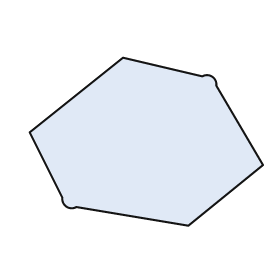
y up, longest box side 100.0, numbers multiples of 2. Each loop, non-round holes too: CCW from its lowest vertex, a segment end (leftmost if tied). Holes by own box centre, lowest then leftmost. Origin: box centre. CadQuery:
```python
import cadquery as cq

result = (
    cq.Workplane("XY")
    .moveTo(18.0, -36.0)
    .lineTo(50.0, -10.0)
    .lineTo(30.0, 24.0)
    .threePointArc((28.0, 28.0), (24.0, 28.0))
    .lineTo(-10.0, 36.0)
    .lineTo(-50.0, 4.0)
    .lineTo(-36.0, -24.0)
    .threePointArc((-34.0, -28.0), (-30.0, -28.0))
    .close()
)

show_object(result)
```